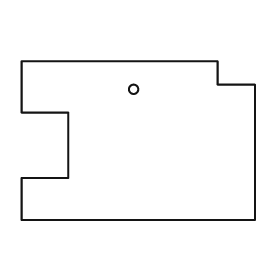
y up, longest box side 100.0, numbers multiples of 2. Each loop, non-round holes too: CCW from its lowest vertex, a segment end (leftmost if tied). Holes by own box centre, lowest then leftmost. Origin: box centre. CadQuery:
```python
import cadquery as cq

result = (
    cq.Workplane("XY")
    .moveTo(-50.0, -34.0)
    .lineTo(50.0, -34.0)
    .lineTo(50.0, 24.0)
    .lineTo(34.0, 24.0)
    .lineTo(34.0, 34.0)
    .lineTo(-50.0, 34.0)
    .lineTo(-50.0, 12.0)
    .lineTo(-30.0, 12.0)
    .lineTo(-30.0, -16.0)
    .lineTo(-50.0, -16.0)
    .close()
    .moveTo(-2.0, 22.0)
    .circle(2.0)
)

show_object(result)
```